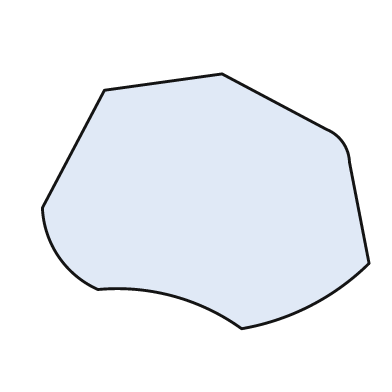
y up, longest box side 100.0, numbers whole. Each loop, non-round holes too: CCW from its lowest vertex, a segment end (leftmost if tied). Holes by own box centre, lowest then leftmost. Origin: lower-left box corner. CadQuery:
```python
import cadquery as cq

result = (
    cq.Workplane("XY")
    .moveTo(61.0, 0.0)
    .threePointArc((82.0, 7.0), (100.0, 20.0))
    .lineTo(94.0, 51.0)
    .threePointArc((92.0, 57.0), (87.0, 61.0))
    .lineTo(55.0, 78.0)
    .lineTo(19.0, 73.0)
    .lineTo(0.0, 37.0)
    .threePointArc((5.0, 22.0), (17.0, 12.0))
    .threePointArc((40.0, 10.0), (61.0, 0.0))
    .close()
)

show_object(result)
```